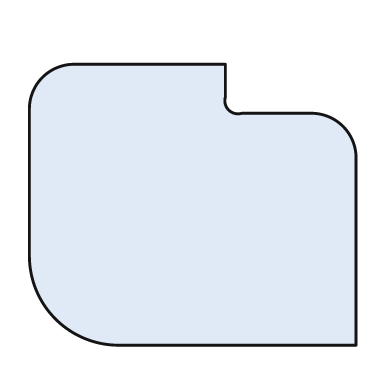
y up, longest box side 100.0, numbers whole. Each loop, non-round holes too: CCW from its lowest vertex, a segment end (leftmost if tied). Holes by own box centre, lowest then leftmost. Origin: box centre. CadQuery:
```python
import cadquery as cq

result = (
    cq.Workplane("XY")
    .moveTo(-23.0, -43.0)
    .lineTo(50.0, -43.0)
    .lineTo(50.0, 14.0)
    .threePointArc((46.0, 24.0), (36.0, 28.0))
    .lineTo(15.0, 28.0)
    .threePointArc((11.0, 29.0), (10.0, 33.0))
    .lineTo(10.0, 43.0)
    .lineTo(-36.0, 43.0)
    .threePointArc((-46.0, 39.0), (-50.0, 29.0))
    .lineTo(-50.0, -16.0)
    .threePointArc((-42.0, -35.0), (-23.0, -43.0))
    .close()
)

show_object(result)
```